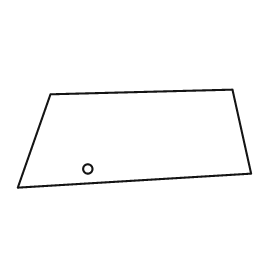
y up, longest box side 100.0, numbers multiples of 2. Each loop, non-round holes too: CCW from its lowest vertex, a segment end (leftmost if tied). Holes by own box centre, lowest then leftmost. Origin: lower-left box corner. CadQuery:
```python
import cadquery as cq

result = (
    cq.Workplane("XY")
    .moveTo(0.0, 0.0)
    .lineTo(100.0, 6.0)
    .lineTo(92.0, 42.0)
    .lineTo(14.0, 40.0)
    .close()
    .moveTo(30.0, 8.0)
    .circle(2.0)
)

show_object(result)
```